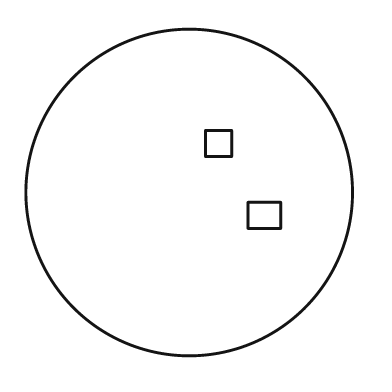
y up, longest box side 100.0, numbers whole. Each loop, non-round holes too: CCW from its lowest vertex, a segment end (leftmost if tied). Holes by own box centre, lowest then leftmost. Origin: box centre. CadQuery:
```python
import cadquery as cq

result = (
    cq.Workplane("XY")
    .moveTo(0.0, 0.0)
    .circle(50.0)
    .moveTo(18.0, -11.0)
    .lineTo(28.0, -11.0)
    .lineTo(28.0, -3.0)
    .lineTo(18.0, -3.0)
    .close()
    .moveTo(5.0, 11.0)
    .lineTo(13.0, 11.0)
    .lineTo(13.0, 19.0)
    .lineTo(5.0, 19.0)
    .close()
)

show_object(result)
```